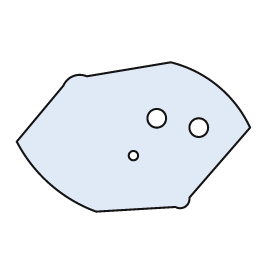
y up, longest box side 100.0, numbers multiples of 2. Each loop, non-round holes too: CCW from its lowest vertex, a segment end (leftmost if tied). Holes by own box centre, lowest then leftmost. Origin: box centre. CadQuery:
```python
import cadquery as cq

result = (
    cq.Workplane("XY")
    .moveTo(-16.0, -32.0)
    .lineTo(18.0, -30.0)
    .threePointArc((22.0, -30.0), (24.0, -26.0))
    .lineTo(50.0, 4.0)
    .threePointArc((36.0, 22.0), (16.0, 32.0))
    .lineTo(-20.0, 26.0)
    .threePointArc((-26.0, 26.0), (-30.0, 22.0))
    .lineTo(-50.0, -2.0)
    .threePointArc((-36.0, -20.0), (-16.0, -32.0))
    .close()
    .moveTo(0.0, -8.0)
    .circle(2.0)
    .moveTo(28.0, 4.0)
    .circle(4.0)
    .moveTo(10.0, 8.0)
    .circle(4.0)
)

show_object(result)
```